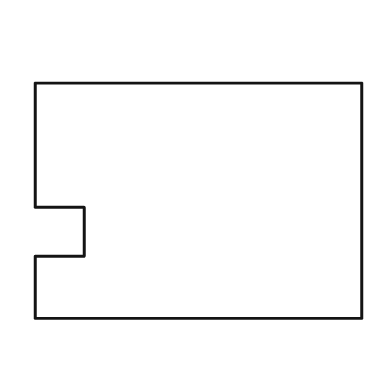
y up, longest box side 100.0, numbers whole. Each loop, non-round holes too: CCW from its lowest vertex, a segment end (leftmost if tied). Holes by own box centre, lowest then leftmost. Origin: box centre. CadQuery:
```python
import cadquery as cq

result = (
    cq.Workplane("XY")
    .moveTo(-50.0, -36.0)
    .lineTo(50.0, -36.0)
    .lineTo(50.0, 36.0)
    .lineTo(-50.0, 36.0)
    .lineTo(-50.0, -2.0)
    .lineTo(-35.0, -2.0)
    .lineTo(-35.0, -17.0)
    .lineTo(-50.0, -17.0)
    .close()
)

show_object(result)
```